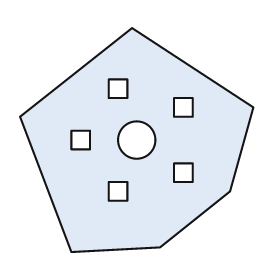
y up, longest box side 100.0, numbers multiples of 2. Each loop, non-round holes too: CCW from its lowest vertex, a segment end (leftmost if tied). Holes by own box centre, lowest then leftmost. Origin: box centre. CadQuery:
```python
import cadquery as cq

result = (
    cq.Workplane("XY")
    .moveTo(-28.0, -48.0)
    .lineTo(10.0, -46.0)
    .lineTo(40.0, -22.0)
    .lineTo(50.0, 14.0)
    .lineTo(-2.0, 48.0)
    .lineTo(-50.0, 10.0)
    .close()
    .moveTo(-12.0, -26.0)
    .lineTo(-4.0, -26.0)
    .lineTo(-4.0, -18.0)
    .lineTo(-12.0, -18.0)
    .close()
    .moveTo(16.0, -18.0)
    .lineTo(24.0, -18.0)
    .lineTo(24.0, -10.0)
    .lineTo(16.0, -10.0)
    .close()
    .moveTo(-28.0, -4.0)
    .lineTo(-20.0, -4.0)
    .lineTo(-20.0, 4.0)
    .lineTo(-28.0, 4.0)
    .close()
    .moveTo(0.0, 0.0)
    .circle(8.0)
    .moveTo(16.0, 10.0)
    .lineTo(24.0, 10.0)
    .lineTo(24.0, 18.0)
    .lineTo(16.0, 18.0)
    .close()
    .moveTo(-12.0, 18.0)
    .lineTo(-4.0, 18.0)
    .lineTo(-4.0, 26.0)
    .lineTo(-12.0, 26.0)
    .close()
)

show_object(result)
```